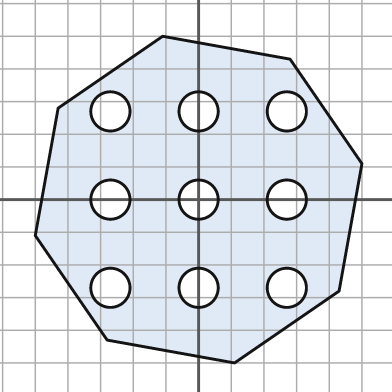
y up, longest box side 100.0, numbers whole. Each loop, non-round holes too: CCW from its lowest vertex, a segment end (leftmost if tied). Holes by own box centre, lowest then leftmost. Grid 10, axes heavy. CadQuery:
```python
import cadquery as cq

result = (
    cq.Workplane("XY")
    .moveTo(11.0, -50.0)
    .lineTo(43.0, -28.0)
    .lineTo(50.0, 11.0)
    .lineTo(28.0, 43.0)
    .lineTo(-11.0, 50.0)
    .lineTo(-43.0, 28.0)
    .lineTo(-50.0, -11.0)
    .lineTo(-28.0, -43.0)
    .close()
    .moveTo(-27.0, -27.0)
    .circle(6.0)
    .moveTo(0.0, -27.0)
    .circle(6.0)
    .moveTo(27.0, -27.0)
    .circle(6.0)
    .moveTo(-27.0, 0.0)
    .circle(6.0)
    .moveTo(0.0, 0.0)
    .circle(6.0)
    .moveTo(27.0, 0.0)
    .circle(6.0)
    .moveTo(-27.0, 27.0)
    .circle(6.0)
    .moveTo(0.0, 27.0)
    .circle(6.0)
    .moveTo(27.0, 27.0)
    .circle(6.0)
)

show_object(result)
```